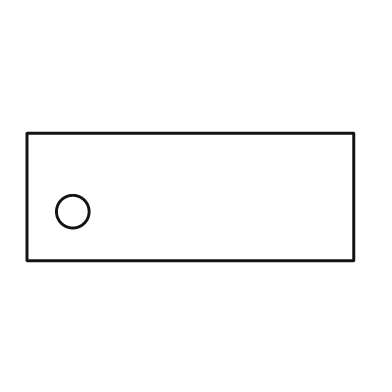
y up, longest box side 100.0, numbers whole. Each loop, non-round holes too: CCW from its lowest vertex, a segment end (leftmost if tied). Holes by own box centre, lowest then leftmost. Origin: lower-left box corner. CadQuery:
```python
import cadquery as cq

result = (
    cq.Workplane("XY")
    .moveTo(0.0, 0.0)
    .lineTo(100.0, 0.0)
    .lineTo(100.0, 39.0)
    .lineTo(0.0, 39.0)
    .close()
    .moveTo(14.0, 15.0)
    .circle(5.0)
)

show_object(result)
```